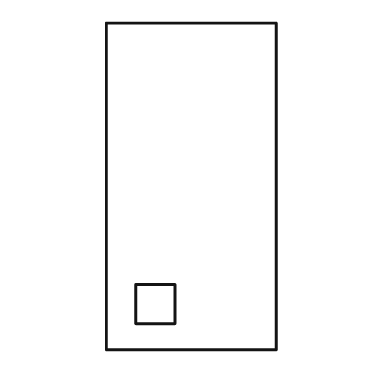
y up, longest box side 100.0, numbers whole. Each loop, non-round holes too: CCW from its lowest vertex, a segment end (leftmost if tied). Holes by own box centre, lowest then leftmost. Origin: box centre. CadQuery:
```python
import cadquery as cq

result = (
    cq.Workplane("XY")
    .moveTo(-26.0, -50.0)
    .lineTo(26.0, -50.0)
    .lineTo(26.0, 50.0)
    .lineTo(-26.0, 50.0)
    .close()
    .moveTo(-17.0, -42.0)
    .lineTo(-5.0, -42.0)
    .lineTo(-5.0, -30.0)
    .lineTo(-17.0, -30.0)
    .close()
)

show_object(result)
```